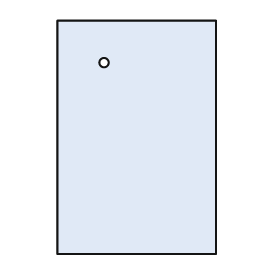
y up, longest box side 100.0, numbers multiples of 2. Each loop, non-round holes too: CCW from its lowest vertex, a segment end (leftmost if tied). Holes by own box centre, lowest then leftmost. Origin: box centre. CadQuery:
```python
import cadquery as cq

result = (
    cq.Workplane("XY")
    .moveTo(-34.0, -50.0)
    .lineTo(34.0, -50.0)
    .lineTo(34.0, 50.0)
    .lineTo(-34.0, 50.0)
    .close()
    .moveTo(-14.0, 32.0)
    .circle(2.0)
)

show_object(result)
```